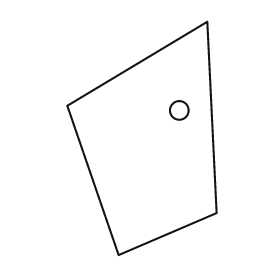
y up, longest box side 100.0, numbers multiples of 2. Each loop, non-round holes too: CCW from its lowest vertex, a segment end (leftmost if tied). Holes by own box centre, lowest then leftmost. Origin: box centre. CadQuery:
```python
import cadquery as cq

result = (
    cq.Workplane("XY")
    .moveTo(-10.0, -50.0)
    .lineTo(32.0, -32.0)
    .lineTo(28.0, 50.0)
    .lineTo(-32.0, 14.0)
    .close()
    .moveTo(16.0, 12.0)
    .circle(4.0)
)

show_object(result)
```